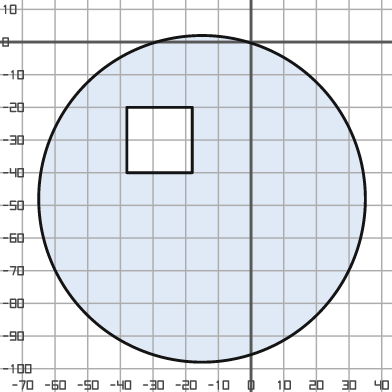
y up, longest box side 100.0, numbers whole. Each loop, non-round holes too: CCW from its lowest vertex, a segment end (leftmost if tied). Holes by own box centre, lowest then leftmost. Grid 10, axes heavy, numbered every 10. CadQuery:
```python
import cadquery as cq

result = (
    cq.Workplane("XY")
    .moveTo(-15.0, -48.0)
    .circle(50.0)
    .moveTo(-38.0, -40.0)
    .lineTo(-18.0, -40.0)
    .lineTo(-18.0, -20.0)
    .lineTo(-38.0, -20.0)
    .close()
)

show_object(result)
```